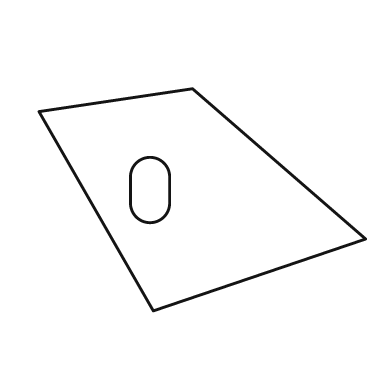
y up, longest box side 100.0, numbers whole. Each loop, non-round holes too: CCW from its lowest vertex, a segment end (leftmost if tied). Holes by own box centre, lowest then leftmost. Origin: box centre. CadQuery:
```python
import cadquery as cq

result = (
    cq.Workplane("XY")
    .moveTo(-15.0, -34.0)
    .lineTo(50.0, -12.0)
    .lineTo(-3.0, 34.0)
    .lineTo(-50.0, 27.0)
    .close()
    .moveTo(-22.0, -1.0)
    .threePointArc((-16.0, -7.0), (-10.0, -1.0))
    .lineTo(-10.0, 7.0)
    .threePointArc((-16.0, 13.0), (-22.0, 7.0))
    .close()
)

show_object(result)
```